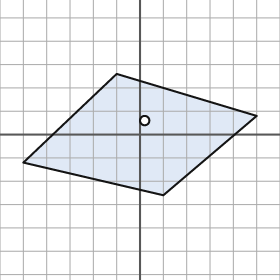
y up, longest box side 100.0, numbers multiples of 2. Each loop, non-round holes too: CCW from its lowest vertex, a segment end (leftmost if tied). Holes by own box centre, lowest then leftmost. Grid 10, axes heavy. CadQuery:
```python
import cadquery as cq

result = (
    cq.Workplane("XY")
    .moveTo(10.0, -26.0)
    .lineTo(50.0, 8.0)
    .lineTo(-10.0, 26.0)
    .lineTo(-50.0, -12.0)
    .close()
    .moveTo(2.0, 6.0)
    .circle(2.0)
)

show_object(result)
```